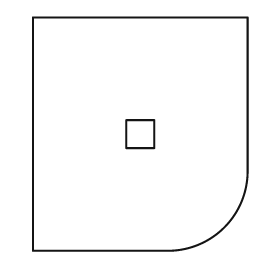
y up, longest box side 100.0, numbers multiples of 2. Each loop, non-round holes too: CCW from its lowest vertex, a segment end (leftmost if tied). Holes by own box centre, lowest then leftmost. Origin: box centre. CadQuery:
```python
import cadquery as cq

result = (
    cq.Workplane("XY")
    .moveTo(-46.0, -50.0)
    .lineTo(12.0, -50.0)
    .threePointArc((36.0, -40.0), (46.0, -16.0))
    .lineTo(46.0, 50.0)
    .lineTo(-46.0, 50.0)
    .close()
    .moveTo(-6.0, -6.0)
    .lineTo(6.0, -6.0)
    .lineTo(6.0, 6.0)
    .lineTo(-6.0, 6.0)
    .close()
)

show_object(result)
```